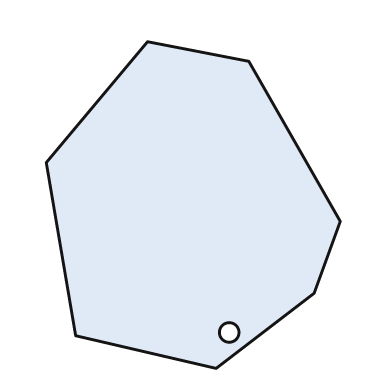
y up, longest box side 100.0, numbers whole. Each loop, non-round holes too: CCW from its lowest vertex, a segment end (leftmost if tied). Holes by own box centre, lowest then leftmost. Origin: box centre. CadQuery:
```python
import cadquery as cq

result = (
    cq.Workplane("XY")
    .moveTo(7.0, -50.0)
    .lineTo(37.0, -27.0)
    .lineTo(45.0, -5.0)
    .lineTo(17.0, 44.0)
    .lineTo(-14.0, 50.0)
    .lineTo(-45.0, 13.0)
    .lineTo(-36.0, -40.0)
    .close()
    .moveTo(11.0, -39.0)
    .circle(3.0)
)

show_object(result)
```